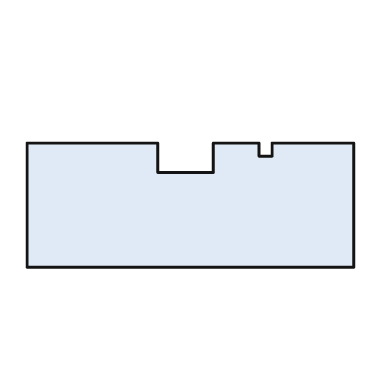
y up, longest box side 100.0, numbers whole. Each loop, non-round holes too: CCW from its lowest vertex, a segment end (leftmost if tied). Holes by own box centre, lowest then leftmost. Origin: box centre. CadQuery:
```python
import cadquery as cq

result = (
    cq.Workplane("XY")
    .moveTo(-50.0, -19.0)
    .lineTo(50.0, -19.0)
    .lineTo(50.0, 19.0)
    .lineTo(25.0, 19.0)
    .lineTo(25.0, 15.0)
    .lineTo(21.0, 15.0)
    .lineTo(21.0, 19.0)
    .lineTo(7.0, 19.0)
    .lineTo(7.0, 10.0)
    .lineTo(-10.0, 10.0)
    .lineTo(-10.0, 19.0)
    .lineTo(-50.0, 19.0)
    .close()
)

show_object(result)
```